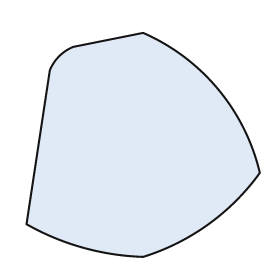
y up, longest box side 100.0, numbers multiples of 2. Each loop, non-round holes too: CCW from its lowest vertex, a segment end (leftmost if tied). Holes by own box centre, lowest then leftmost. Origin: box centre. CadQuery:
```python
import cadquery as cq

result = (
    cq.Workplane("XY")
    .moveTo(0.0, -48.0)
    .threePointArc((28.0, -34.0), (50.0, -12.0))
    .threePointArc((32.0, 24.0), (0.0, 48.0))
    .lineTo(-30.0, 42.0)
    .threePointArc((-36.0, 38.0), (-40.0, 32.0))
    .lineTo(-50.0, -34.0)
    .threePointArc((-26.0, -44.0), (0.0, -48.0))
    .close()
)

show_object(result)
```